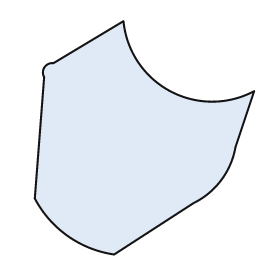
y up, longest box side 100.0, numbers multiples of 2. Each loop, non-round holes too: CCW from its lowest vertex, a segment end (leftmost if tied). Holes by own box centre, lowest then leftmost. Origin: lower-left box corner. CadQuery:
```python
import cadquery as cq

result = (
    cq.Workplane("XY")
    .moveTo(34.0, 0.0)
    .lineTo(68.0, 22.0)
    .threePointArc((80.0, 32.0), (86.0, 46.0))
    .lineTo(94.0, 70.0)
    .threePointArc((58.0, 70.0), (38.0, 100.0))
    .lineTo(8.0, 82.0)
    .threePointArc((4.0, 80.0), (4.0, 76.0))
    .lineTo(0.0, 24.0)
    .threePointArc((14.0, 8.0), (34.0, 0.0))
    .close()
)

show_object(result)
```